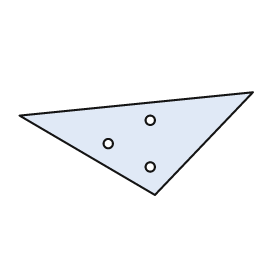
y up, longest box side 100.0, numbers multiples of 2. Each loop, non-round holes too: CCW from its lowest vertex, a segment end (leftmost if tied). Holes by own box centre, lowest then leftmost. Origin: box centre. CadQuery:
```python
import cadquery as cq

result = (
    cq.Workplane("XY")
    .moveTo(8.0, -22.0)
    .lineTo(50.0, 22.0)
    .lineTo(-50.0, 12.0)
    .close()
    .moveTo(6.0, -10.0)
    .circle(2.0)
    .moveTo(-12.0, 0.0)
    .circle(2.0)
    .moveTo(6.0, 10.0)
    .circle(2.0)
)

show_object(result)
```